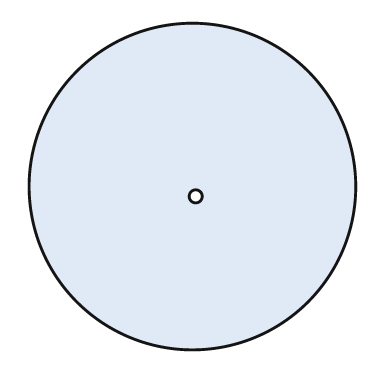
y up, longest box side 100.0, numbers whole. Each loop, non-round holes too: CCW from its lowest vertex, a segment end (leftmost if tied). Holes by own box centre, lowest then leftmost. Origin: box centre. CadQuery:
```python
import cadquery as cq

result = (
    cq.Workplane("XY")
    .moveTo(0.0, 0.0)
    .circle(50.0)
    .moveTo(1.0, -3.0)
    .circle(2.0)
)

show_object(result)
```